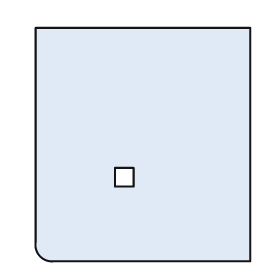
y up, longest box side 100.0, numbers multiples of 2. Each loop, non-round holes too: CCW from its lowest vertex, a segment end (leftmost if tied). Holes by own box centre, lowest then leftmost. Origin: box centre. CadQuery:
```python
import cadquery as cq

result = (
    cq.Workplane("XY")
    .moveTo(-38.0, -50.0)
    .lineTo(46.0, -50.0)
    .lineTo(46.0, 50.0)
    .lineTo(-46.0, 50.0)
    .lineTo(-46.0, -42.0)
    .threePointArc((-44.0, -48.0), (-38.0, -50.0))
    .close()
    .moveTo(-12.0, -18.0)
    .lineTo(-4.0, -18.0)
    .lineTo(-4.0, -10.0)
    .lineTo(-12.0, -10.0)
    .close()
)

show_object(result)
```